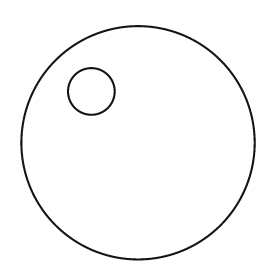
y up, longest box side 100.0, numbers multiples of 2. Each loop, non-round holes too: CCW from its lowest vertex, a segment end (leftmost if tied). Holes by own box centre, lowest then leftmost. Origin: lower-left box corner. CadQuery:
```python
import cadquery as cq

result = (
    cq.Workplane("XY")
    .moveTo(50.0, 50.0)
    .circle(50.0)
    .moveTo(30.0, 72.0)
    .circle(10.0)
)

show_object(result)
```